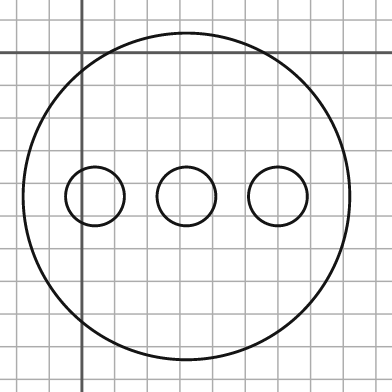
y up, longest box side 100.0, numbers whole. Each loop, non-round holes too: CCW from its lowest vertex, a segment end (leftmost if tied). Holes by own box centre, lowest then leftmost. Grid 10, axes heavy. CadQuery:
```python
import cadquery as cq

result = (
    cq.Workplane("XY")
    .moveTo(32.0, -44.0)
    .circle(50.0)
    .moveTo(4.0, -44.0)
    .circle(9.0)
    .moveTo(32.0, -44.0)
    .circle(9.0)
    .moveTo(60.0, -44.0)
    .circle(9.0)
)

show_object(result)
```